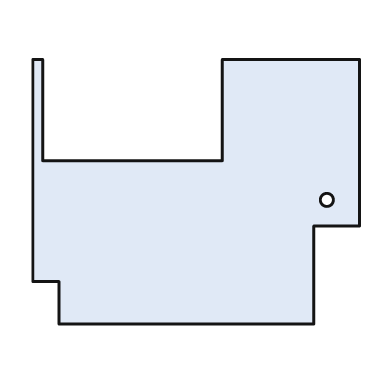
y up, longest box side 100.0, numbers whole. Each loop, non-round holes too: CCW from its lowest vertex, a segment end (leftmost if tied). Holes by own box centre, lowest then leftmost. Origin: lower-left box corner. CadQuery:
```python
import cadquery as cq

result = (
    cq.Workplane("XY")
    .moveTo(8.0, 0.0)
    .lineTo(86.0, 0.0)
    .lineTo(86.0, 30.0)
    .lineTo(100.0, 30.0)
    .lineTo(100.0, 81.0)
    .lineTo(58.0, 81.0)
    .lineTo(58.0, 50.0)
    .lineTo(3.0, 50.0)
    .lineTo(3.0, 81.0)
    .lineTo(0.0, 81.0)
    .lineTo(0.0, 13.0)
    .lineTo(8.0, 13.0)
    .close()
    .moveTo(90.0, 38.0)
    .circle(2.0)
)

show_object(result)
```